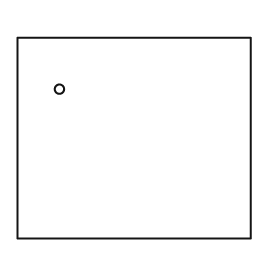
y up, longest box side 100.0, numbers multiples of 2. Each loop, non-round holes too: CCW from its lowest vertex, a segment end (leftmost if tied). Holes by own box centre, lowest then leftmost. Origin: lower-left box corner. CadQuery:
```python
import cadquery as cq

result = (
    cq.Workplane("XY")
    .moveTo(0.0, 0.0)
    .lineTo(100.0, 0.0)
    .lineTo(100.0, 86.0)
    .lineTo(0.0, 86.0)
    .close()
    .moveTo(18.0, 64.0)
    .circle(2.0)
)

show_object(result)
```